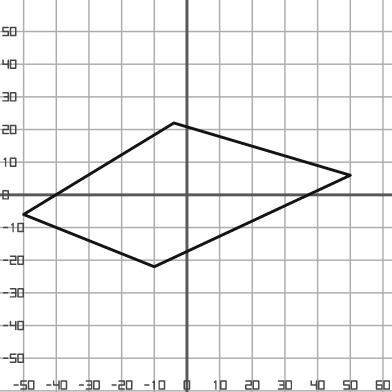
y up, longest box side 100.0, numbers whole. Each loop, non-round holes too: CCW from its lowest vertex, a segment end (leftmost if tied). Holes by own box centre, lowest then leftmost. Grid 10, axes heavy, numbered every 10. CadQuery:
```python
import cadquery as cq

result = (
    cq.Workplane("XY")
    .moveTo(-10.0, -22.0)
    .lineTo(50.0, 6.0)
    .lineTo(-4.0, 22.0)
    .lineTo(-50.0, -6.0)
    .close()
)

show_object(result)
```